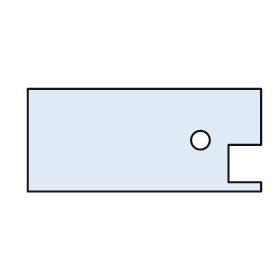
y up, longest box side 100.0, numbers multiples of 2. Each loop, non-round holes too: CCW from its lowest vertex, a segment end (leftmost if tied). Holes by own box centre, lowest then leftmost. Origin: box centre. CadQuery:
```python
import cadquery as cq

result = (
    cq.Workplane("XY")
    .moveTo(-50.0, -22.0)
    .lineTo(50.0, -22.0)
    .lineTo(50.0, -18.0)
    .lineTo(36.0, -18.0)
    .lineTo(36.0, -2.0)
    .lineTo(50.0, -2.0)
    .lineTo(50.0, 22.0)
    .lineTo(-50.0, 22.0)
    .close()
    .moveTo(24.0, 0.0)
    .circle(4.0)
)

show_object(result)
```